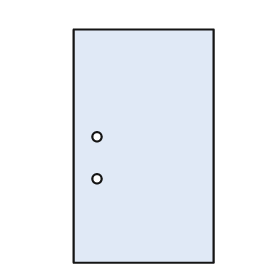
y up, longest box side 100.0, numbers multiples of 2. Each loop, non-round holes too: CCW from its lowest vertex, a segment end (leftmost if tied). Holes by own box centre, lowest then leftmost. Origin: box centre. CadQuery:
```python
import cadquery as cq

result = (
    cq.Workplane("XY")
    .moveTo(-30.0, -50.0)
    .lineTo(30.0, -50.0)
    .lineTo(30.0, 50.0)
    .lineTo(-30.0, 50.0)
    .close()
    .moveTo(-20.0, -14.0)
    .circle(2.0)
    .moveTo(-20.0, 4.0)
    .circle(2.0)
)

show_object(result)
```